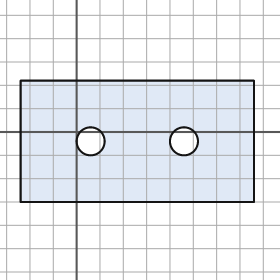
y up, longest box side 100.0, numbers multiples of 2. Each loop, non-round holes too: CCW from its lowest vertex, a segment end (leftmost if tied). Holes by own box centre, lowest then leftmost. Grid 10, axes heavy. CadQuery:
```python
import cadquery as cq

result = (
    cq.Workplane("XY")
    .moveTo(-24.0, -30.0)
    .lineTo(76.0, -30.0)
    .lineTo(76.0, 22.0)
    .lineTo(-24.0, 22.0)
    .close()
    .moveTo(6.0, -4.0)
    .circle(6.0)
    .moveTo(46.0, -4.0)
    .circle(6.0)
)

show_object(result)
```